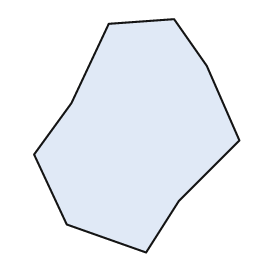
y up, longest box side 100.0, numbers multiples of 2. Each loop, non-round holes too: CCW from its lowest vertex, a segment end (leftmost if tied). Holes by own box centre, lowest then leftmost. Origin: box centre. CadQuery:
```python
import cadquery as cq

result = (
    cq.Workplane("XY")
    .moveTo(4.0, -50.0)
    .lineTo(18.0, -28.0)
    .lineTo(44.0, -2.0)
    .lineTo(30.0, 30.0)
    .lineTo(16.0, 50.0)
    .lineTo(-12.0, 48.0)
    .lineTo(-28.0, 14.0)
    .lineTo(-44.0, -8.0)
    .lineTo(-30.0, -38.0)
    .close()
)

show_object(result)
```